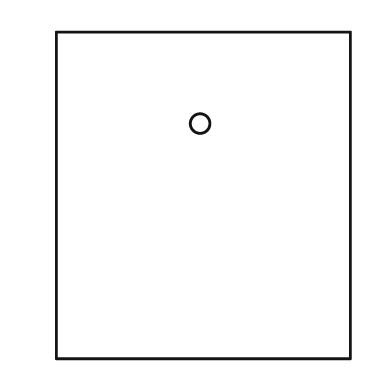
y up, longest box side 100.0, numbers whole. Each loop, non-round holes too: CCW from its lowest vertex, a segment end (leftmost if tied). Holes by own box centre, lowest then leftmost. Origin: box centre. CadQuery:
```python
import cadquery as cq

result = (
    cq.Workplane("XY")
    .moveTo(-45.0, -50.0)
    .lineTo(45.0, -50.0)
    .lineTo(45.0, 50.0)
    .lineTo(-45.0, 50.0)
    .close()
    .moveTo(-1.0, 22.0)
    .circle(3.0)
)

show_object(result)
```